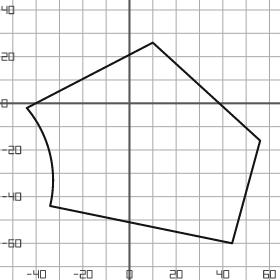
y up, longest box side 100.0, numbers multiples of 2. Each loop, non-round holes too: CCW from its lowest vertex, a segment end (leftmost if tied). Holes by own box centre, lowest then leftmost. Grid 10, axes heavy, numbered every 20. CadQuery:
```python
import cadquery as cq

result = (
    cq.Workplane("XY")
    .moveTo(44.0, -60.0)
    .lineTo(56.0, -16.0)
    .lineTo(10.0, 26.0)
    .lineTo(-44.0, -2.0)
    .threePointArc((-34.0, -22.0), (-34.0, -44.0))
    .close()
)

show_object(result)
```